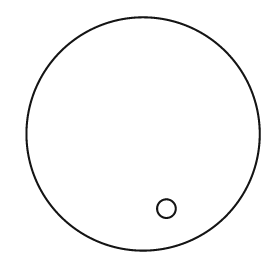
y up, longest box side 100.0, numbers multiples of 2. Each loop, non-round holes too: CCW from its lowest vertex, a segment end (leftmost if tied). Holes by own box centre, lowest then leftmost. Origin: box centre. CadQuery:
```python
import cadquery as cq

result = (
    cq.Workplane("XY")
    .moveTo(0.0, 0.0)
    .circle(50.0)
    .moveTo(10.0, -32.0)
    .circle(4.0)
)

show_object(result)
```